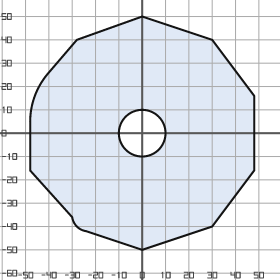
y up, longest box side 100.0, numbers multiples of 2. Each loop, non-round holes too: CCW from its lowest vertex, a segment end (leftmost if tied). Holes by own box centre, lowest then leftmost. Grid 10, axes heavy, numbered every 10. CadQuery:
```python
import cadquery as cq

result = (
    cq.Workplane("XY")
    .moveTo(0.0, -50.0)
    .lineTo(30.0, -40.0)
    .lineTo(48.0, -16.0)
    .lineTo(48.0, 16.0)
    .lineTo(30.0, 40.0)
    .lineTo(0.0, 50.0)
    .lineTo(-28.0, 40.0)
    .lineTo(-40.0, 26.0)
    .threePointArc((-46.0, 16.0), (-48.0, 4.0))
    .lineTo(-48.0, -16.0)
    .lineTo(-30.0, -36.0)
    .threePointArc((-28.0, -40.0), (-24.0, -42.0))
    .close()
    .moveTo(0.0, 0.0)
    .circle(10.0)
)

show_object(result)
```